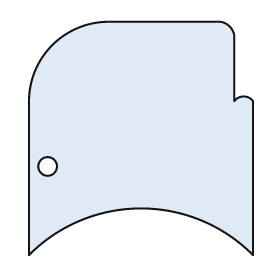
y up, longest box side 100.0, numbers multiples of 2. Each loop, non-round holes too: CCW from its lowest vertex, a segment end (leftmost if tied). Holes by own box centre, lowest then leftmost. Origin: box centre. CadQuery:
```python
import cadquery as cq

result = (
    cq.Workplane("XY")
    .moveTo(-48.0, -50.0)
    .threePointArc((0.0, -30.0), (48.0, -50.0))
    .lineTo(48.0, 16.0)
    .threePointArc((44.0, 18.0), (40.0, 16.0))
    .lineTo(40.0, 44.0)
    .threePointArc((38.0, 48.0), (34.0, 50.0))
    .lineTo(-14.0, 50.0)
    .threePointArc((-38.0, 40.0), (-48.0, 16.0))
    .close()
    .moveTo(-40.0, -12.0)
    .circle(4.0)
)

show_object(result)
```